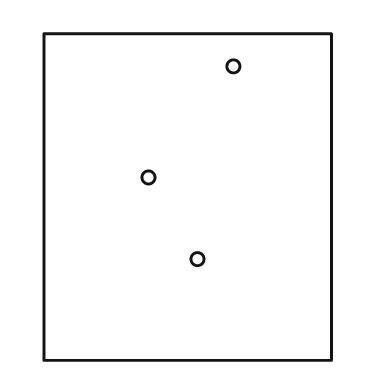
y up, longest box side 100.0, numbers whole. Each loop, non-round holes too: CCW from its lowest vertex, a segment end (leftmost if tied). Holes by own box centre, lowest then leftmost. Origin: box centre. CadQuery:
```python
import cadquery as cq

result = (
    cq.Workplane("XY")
    .moveTo(-44.0, -50.0)
    .lineTo(44.0, -50.0)
    .lineTo(44.0, 50.0)
    .lineTo(-44.0, 50.0)
    .close()
    .moveTo(3.0, -19.0)
    .circle(2.0)
    .moveTo(-12.0, 6.0)
    .circle(2.0)
    .moveTo(14.0, 40.0)
    .circle(2.0)
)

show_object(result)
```